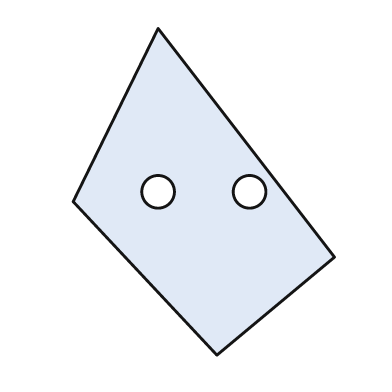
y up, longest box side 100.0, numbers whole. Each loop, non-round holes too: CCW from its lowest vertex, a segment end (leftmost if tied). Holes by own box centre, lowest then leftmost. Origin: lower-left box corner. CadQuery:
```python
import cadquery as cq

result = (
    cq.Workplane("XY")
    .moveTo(44.0, 0.0)
    .lineTo(80.0, 30.0)
    .lineTo(26.0, 100.0)
    .lineTo(0.0, 47.0)
    .close()
    .moveTo(26.0, 50.0)
    .circle(5.0)
    .moveTo(54.0, 50.0)
    .circle(5.0)
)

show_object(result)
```